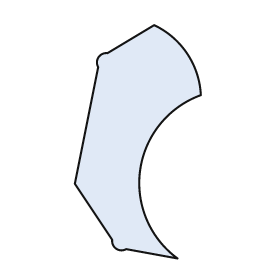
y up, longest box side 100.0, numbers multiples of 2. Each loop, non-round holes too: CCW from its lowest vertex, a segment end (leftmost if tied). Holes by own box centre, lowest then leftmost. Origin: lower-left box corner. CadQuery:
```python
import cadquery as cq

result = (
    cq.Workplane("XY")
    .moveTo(44.0, 0.0)
    .threePointArc((28.0, 38.0), (54.0, 70.0))
    .threePointArc((48.0, 88.0), (34.0, 100.0))
    .lineTo(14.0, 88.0)
    .threePointArc((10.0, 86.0), (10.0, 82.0))
    .lineTo(0.0, 32.0)
    .lineTo(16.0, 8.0)
    .threePointArc((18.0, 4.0), (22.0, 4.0))
    .close()
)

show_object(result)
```